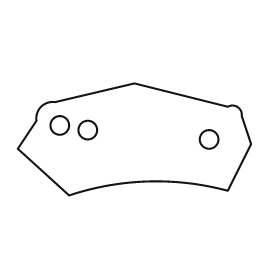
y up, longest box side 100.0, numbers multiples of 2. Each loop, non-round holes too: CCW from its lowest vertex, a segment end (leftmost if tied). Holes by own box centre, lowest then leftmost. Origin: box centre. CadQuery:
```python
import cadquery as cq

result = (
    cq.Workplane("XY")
    .moveTo(-28.0, -24.0)
    .threePointArc((6.0, -18.0), (40.0, -22.0))
    .lineTo(50.0, -2.0)
    .lineTo(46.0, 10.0)
    .threePointArc((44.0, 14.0), (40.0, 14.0))
    .lineTo(0.0, 24.0)
    .lineTo(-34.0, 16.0)
    .threePointArc((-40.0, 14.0), (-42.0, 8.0))
    .lineTo(-50.0, -4.0)
    .close()
    .moveTo(32.0, 0.0)
    .circle(4.0)
    .moveTo(-20.0, 4.0)
    .circle(4.0)
    .moveTo(-32.0, 6.0)
    .circle(4.0)
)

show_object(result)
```